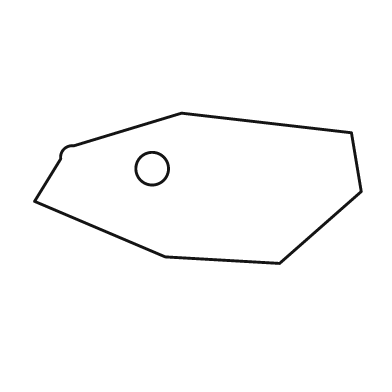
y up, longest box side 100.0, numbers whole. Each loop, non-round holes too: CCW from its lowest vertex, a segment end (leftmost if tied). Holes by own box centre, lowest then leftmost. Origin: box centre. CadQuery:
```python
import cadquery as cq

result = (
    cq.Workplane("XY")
    .moveTo(25.0, -23.0)
    .lineTo(50.0, -1.0)
    .lineTo(47.0, 17.0)
    .lineTo(-5.0, 23.0)
    .lineTo(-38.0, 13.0)
    .threePointArc((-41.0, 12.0), (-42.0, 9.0))
    .lineTo(-50.0, -4.0)
    .lineTo(-10.0, -21.0)
    .close()
    .moveTo(-14.0, 6.0)
    .circle(5.0)
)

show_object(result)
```